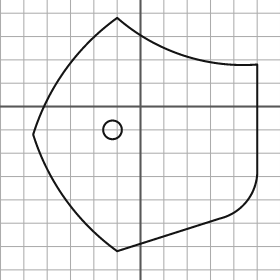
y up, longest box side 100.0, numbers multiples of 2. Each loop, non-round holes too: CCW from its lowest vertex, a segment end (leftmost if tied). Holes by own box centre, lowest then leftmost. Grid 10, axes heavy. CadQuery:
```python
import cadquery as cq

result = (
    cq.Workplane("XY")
    .moveTo(-10.0, -62.0)
    .lineTo(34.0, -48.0)
    .threePointArc((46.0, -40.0), (50.0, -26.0))
    .lineTo(50.0, 18.0)
    .threePointArc((18.0, 22.0), (-10.0, 38.0))
    .threePointArc((-32.0, 16.0), (-46.0, -12.0))
    .threePointArc((-32.0, -40.0), (-10.0, -62.0))
    .close()
    .moveTo(-12.0, -10.0)
    .circle(4.0)
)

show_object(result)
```